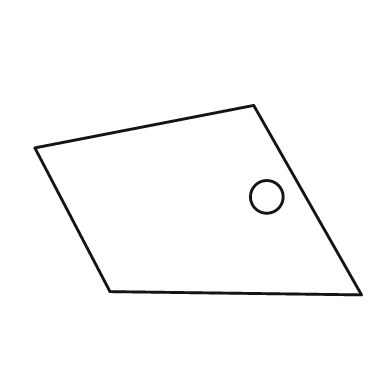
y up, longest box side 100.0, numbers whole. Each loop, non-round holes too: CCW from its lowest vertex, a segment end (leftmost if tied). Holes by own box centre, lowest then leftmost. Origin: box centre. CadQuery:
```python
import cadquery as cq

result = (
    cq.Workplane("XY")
    .moveTo(50.0, -29.0)
    .lineTo(17.0, 29.0)
    .lineTo(-50.0, 16.0)
    .lineTo(-27.0, -28.0)
    .close()
    .moveTo(21.0, 1.0)
    .circle(5.0)
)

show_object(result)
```